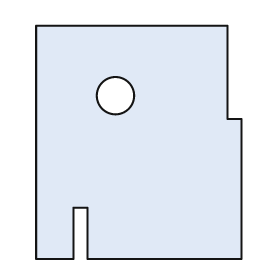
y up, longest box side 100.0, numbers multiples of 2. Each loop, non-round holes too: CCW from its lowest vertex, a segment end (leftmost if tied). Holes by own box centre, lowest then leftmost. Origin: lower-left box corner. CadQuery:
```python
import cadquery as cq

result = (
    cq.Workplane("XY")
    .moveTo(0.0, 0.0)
    .lineTo(16.0, 0.0)
    .lineTo(16.0, 22.0)
    .lineTo(22.0, 22.0)
    .lineTo(22.0, 0.0)
    .lineTo(88.0, 0.0)
    .lineTo(88.0, 60.0)
    .lineTo(82.0, 60.0)
    .lineTo(82.0, 100.0)
    .lineTo(0.0, 100.0)
    .close()
    .moveTo(34.0, 70.0)
    .circle(8.0)
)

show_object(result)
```